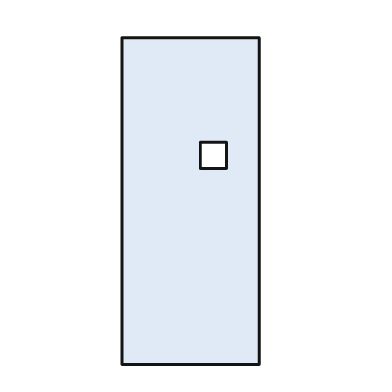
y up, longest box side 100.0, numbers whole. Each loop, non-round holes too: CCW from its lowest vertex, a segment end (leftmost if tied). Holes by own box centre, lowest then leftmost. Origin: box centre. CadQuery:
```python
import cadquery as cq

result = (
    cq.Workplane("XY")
    .moveTo(-21.0, -50.0)
    .lineTo(21.0, -50.0)
    .lineTo(21.0, 50.0)
    .lineTo(-21.0, 50.0)
    .close()
    .moveTo(3.0, 10.0)
    .lineTo(11.0, 10.0)
    .lineTo(11.0, 18.0)
    .lineTo(3.0, 18.0)
    .close()
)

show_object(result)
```